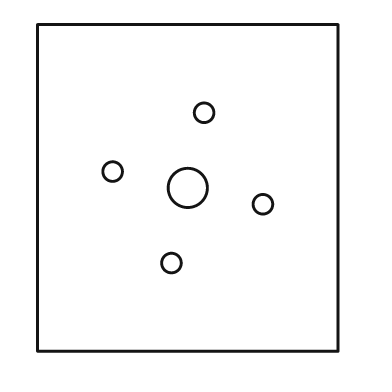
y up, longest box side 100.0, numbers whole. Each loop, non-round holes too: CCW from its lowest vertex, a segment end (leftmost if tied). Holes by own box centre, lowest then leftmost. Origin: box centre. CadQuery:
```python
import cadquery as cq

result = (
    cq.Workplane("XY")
    .moveTo(-46.0, -50.0)
    .lineTo(46.0, -50.0)
    .lineTo(46.0, 50.0)
    .lineTo(-46.0, 50.0)
    .close()
    .moveTo(-5.0, -23.0)
    .circle(3.0)
    .moveTo(23.0, -5.0)
    .circle(3.0)
    .moveTo(0.0, 0.0)
    .circle(6.0)
    .moveTo(-23.0, 5.0)
    .circle(3.0)
    .moveTo(5.0, 23.0)
    .circle(3.0)
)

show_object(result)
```